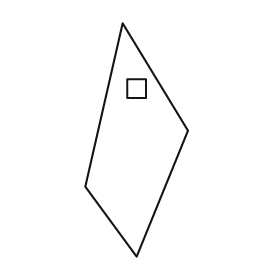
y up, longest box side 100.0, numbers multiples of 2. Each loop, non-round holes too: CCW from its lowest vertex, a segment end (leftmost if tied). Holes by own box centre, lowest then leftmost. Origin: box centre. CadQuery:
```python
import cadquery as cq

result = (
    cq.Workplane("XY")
    .moveTo(0.0, -50.0)
    .lineTo(22.0, 4.0)
    .lineTo(-6.0, 50.0)
    .lineTo(-22.0, -20.0)
    .close()
    .moveTo(-4.0, 18.0)
    .lineTo(4.0, 18.0)
    .lineTo(4.0, 26.0)
    .lineTo(-4.0, 26.0)
    .close()
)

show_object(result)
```